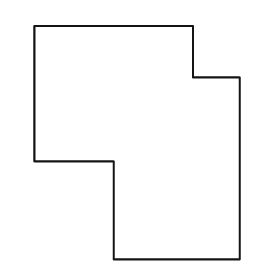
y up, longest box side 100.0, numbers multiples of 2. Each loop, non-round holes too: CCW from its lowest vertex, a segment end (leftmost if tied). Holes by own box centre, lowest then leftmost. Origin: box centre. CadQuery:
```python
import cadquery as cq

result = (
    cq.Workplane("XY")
    .moveTo(-10.0, -50.0)
    .lineTo(44.0, -50.0)
    .lineTo(44.0, 28.0)
    .lineTo(24.0, 28.0)
    .lineTo(24.0, 50.0)
    .lineTo(-44.0, 50.0)
    .lineTo(-44.0, -8.0)
    .lineTo(-10.0, -8.0)
    .close()
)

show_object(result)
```